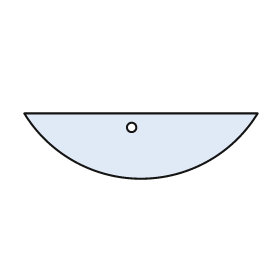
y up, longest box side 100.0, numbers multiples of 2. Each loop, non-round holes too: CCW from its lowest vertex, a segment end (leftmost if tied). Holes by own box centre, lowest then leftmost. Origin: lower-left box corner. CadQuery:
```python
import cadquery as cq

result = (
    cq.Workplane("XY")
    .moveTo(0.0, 28.0)
    .threePointArc((50.0, 0.0), (100.0, 28.0))
    .close()
    .moveTo(46.0, 22.0)
    .circle(2.0)
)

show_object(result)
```